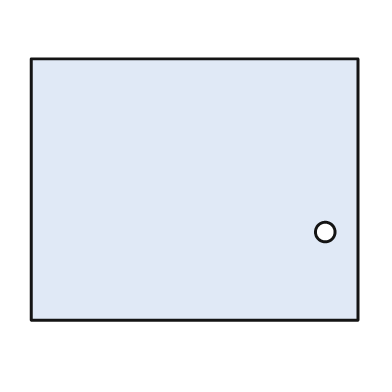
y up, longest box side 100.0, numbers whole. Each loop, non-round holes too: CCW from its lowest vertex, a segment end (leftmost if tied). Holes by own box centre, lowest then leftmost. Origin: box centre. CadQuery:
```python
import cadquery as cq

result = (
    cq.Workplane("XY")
    .moveTo(-50.0, -40.0)
    .lineTo(50.0, -40.0)
    .lineTo(50.0, 40.0)
    .lineTo(-50.0, 40.0)
    .close()
    .moveTo(40.0, -13.0)
    .circle(3.0)
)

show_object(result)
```